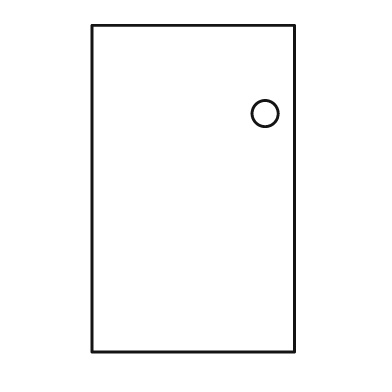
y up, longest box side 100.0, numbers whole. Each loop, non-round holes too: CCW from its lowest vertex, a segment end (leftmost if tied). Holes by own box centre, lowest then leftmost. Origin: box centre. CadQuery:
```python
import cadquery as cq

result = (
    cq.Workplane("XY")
    .moveTo(-31.0, -50.0)
    .lineTo(31.0, -50.0)
    .lineTo(31.0, 50.0)
    .lineTo(-31.0, 50.0)
    .close()
    .moveTo(22.0, 23.0)
    .circle(4.0)
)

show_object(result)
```